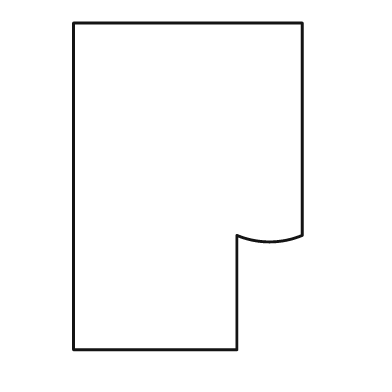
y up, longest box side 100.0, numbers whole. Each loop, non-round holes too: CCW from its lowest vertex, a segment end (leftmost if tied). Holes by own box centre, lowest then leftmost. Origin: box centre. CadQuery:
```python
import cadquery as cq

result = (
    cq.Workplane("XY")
    .moveTo(-35.0, -50.0)
    .lineTo(15.0, -50.0)
    .lineTo(15.0, -15.0)
    .threePointArc((25.0, -17.0), (35.0, -15.0))
    .lineTo(35.0, 50.0)
    .lineTo(-35.0, 50.0)
    .close()
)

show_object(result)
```